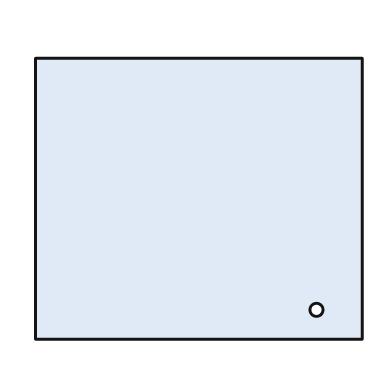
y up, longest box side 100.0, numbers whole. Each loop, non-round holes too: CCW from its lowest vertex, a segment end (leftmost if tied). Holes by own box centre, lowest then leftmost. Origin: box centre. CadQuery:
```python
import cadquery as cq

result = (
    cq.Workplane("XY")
    .moveTo(-50.0, -43.0)
    .lineTo(50.0, -43.0)
    .lineTo(50.0, 43.0)
    .lineTo(-50.0, 43.0)
    .close()
    .moveTo(36.0, -34.0)
    .circle(2.0)
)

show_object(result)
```